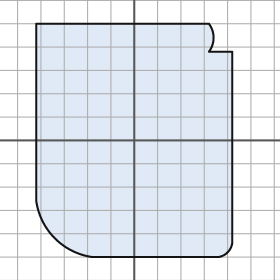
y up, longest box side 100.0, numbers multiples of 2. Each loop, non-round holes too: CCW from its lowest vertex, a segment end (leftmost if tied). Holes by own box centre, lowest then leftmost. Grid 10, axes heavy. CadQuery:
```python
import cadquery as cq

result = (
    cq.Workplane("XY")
    .moveTo(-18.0, -50.0)
    .lineTo(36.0, -50.0)
    .threePointArc((40.0, -48.0), (42.0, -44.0))
    .lineTo(42.0, 38.0)
    .lineTo(32.0, 38.0)
    .threePointArc((34.0, 44.0), (32.0, 50.0))
    .lineTo(-42.0, 50.0)
    .lineTo(-42.0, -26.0)
    .threePointArc((-34.0, -42.0), (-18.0, -50.0))
    .close()
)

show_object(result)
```